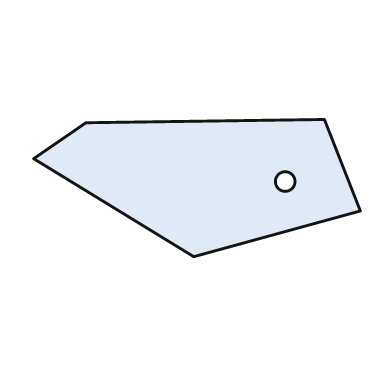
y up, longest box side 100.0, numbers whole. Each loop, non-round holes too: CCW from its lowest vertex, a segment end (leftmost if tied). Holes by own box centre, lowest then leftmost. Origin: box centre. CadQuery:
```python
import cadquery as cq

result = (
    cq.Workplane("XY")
    .moveTo(-1.0, -21.0)
    .lineTo(50.0, -7.0)
    .lineTo(39.0, 21.0)
    .lineTo(-34.0, 20.0)
    .lineTo(-50.0, 9.0)
    .close()
    .moveTo(27.0, 2.0)
    .circle(3.0)
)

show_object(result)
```